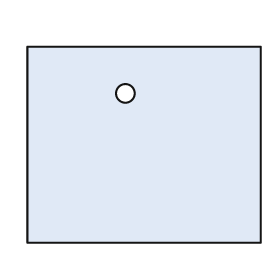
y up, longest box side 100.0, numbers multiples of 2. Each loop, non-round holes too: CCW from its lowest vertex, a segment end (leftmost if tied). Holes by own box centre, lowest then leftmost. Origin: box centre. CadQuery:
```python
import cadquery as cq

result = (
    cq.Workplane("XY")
    .moveTo(-50.0, -42.0)
    .lineTo(50.0, -42.0)
    .lineTo(50.0, 42.0)
    .lineTo(-50.0, 42.0)
    .close()
    .moveTo(-8.0, 22.0)
    .circle(4.0)
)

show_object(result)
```